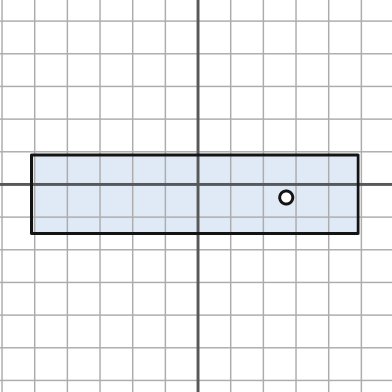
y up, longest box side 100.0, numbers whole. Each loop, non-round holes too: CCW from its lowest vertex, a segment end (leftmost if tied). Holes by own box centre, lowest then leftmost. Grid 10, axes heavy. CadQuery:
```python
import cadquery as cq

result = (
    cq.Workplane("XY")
    .moveTo(-51.0, -15.0)
    .lineTo(49.0, -15.0)
    .lineTo(49.0, 9.0)
    .lineTo(-51.0, 9.0)
    .close()
    .moveTo(27.0, -4.0)
    .circle(2.0)
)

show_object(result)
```